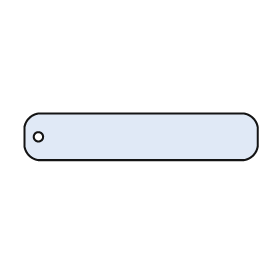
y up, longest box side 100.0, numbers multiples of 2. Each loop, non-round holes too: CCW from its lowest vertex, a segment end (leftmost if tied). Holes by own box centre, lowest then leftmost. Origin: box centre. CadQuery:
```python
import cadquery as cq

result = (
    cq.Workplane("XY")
    .moveTo(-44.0, -10.0)
    .lineTo(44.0, -10.0)
    .threePointArc((48.0, -8.0), (50.0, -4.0))
    .lineTo(50.0, 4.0)
    .threePointArc((48.0, 8.0), (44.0, 10.0))
    .lineTo(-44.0, 10.0)
    .threePointArc((-48.0, 8.0), (-50.0, 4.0))
    .lineTo(-50.0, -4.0)
    .threePointArc((-48.0, -8.0), (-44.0, -10.0))
    .close()
    .moveTo(-44.0, 0.0)
    .circle(2.0)
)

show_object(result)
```